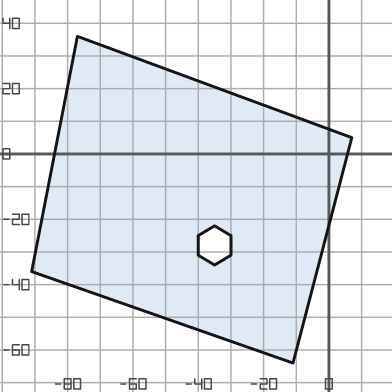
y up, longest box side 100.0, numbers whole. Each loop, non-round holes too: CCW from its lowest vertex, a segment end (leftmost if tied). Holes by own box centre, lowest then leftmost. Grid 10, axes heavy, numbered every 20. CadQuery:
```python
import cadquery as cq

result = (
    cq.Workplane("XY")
    .moveTo(-11.0, -64.0)
    .lineTo(7.0, 5.0)
    .lineTo(-77.0, 36.0)
    .lineTo(-91.0, -36.0)
    .close()
    .moveTo(-35.0, -34.0)
    .lineTo(-30.0, -31.0)
    .lineTo(-30.0, -25.0)
    .lineTo(-35.0, -22.0)
    .lineTo(-40.0, -25.0)
    .lineTo(-40.0, -31.0)
    .close()
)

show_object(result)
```